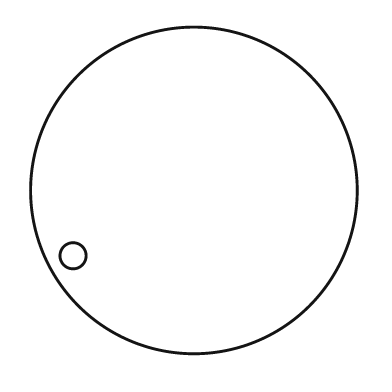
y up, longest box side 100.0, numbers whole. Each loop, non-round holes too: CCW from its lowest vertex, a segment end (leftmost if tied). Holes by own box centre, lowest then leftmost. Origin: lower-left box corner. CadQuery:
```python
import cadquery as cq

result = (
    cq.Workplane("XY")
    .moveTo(50.0, 50.0)
    .circle(50.0)
    .moveTo(13.0, 30.0)
    .circle(4.0)
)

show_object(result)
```